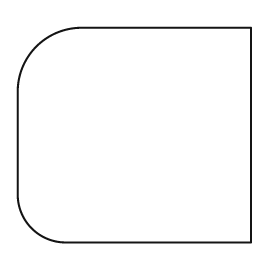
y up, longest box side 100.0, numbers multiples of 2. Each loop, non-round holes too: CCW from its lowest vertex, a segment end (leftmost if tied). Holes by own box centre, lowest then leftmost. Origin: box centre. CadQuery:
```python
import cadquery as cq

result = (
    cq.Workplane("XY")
    .moveTo(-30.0, -46.0)
    .lineTo(50.0, -46.0)
    .lineTo(50.0, 46.0)
    .lineTo(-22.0, 46.0)
    .threePointArc((-42.0, 38.0), (-50.0, 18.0))
    .lineTo(-50.0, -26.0)
    .threePointArc((-44.0, -40.0), (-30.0, -46.0))
    .close()
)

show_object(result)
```